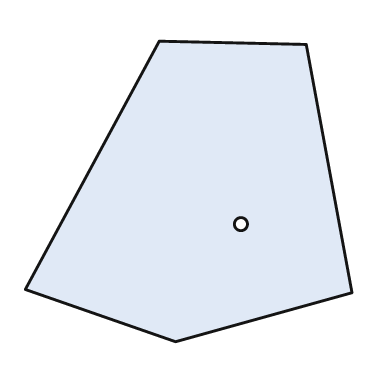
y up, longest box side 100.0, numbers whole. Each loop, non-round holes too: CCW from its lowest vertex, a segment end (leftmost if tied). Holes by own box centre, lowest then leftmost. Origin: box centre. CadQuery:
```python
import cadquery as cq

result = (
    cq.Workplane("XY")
    .moveTo(-4.0, -46.0)
    .lineTo(50.0, -31.0)
    .lineTo(36.0, 45.0)
    .lineTo(-9.0, 46.0)
    .lineTo(-50.0, -30.0)
    .close()
    .moveTo(16.0, -10.0)
    .circle(2.0)
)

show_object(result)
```